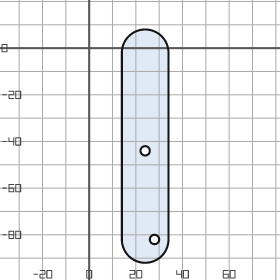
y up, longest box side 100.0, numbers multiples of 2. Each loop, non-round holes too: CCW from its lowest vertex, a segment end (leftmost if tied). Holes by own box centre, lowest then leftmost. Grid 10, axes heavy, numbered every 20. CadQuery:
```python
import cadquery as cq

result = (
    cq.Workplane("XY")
    .moveTo(14.0, -82.0)
    .threePointArc((24.0, -92.0), (34.0, -82.0))
    .lineTo(34.0, -2.0)
    .threePointArc((24.0, 8.0), (14.0, -2.0))
    .close()
    .moveTo(28.0, -82.0)
    .circle(2.0)
    .moveTo(24.0, -44.0)
    .circle(2.0)
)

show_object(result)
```